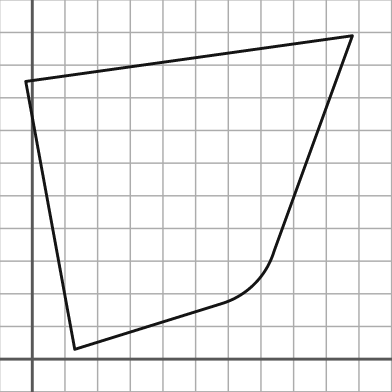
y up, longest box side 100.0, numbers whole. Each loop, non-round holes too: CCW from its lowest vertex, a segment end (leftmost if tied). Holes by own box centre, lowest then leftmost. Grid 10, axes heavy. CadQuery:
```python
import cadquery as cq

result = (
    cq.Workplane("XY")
    .moveTo(13.0, 3.0)
    .lineTo(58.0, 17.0)
    .threePointArc((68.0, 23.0), (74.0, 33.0))
    .lineTo(98.0, 99.0)
    .lineTo(-2.0, 85.0)
    .close()
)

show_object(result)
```